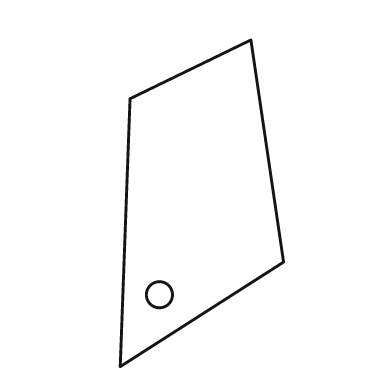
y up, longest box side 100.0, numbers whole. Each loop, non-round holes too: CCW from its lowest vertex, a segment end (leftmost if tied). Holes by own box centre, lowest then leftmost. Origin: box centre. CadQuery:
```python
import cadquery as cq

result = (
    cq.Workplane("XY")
    .moveTo(-25.0, -50.0)
    .lineTo(25.0, -18.0)
    .lineTo(15.0, 50.0)
    .lineTo(-22.0, 32.0)
    .close()
    .moveTo(-13.0, -28.0)
    .circle(4.0)
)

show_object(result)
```